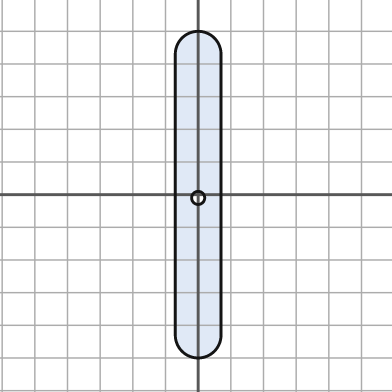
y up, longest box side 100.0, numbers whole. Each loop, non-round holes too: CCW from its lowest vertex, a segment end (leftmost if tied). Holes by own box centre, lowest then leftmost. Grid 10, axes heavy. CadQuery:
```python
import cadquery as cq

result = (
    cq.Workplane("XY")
    .moveTo(-7.0, -43.0)
    .threePointArc((0.0, -50.0), (7.0, -43.0))
    .lineTo(7.0, 43.0)
    .threePointArc((0.0, 50.0), (-7.0, 43.0))
    .close()
    .moveTo(0.0, -1.0)
    .circle(2.0)
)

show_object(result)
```